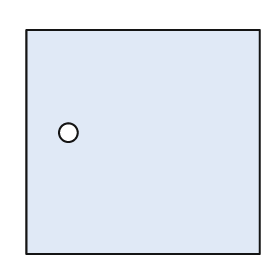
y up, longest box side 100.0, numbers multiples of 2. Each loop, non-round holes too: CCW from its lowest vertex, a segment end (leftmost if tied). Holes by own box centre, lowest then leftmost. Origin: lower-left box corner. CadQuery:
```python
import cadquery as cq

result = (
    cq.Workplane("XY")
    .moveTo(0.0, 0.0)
    .lineTo(100.0, 0.0)
    .lineTo(100.0, 96.0)
    .lineTo(0.0, 96.0)
    .close()
    .moveTo(18.0, 52.0)
    .circle(4.0)
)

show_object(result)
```